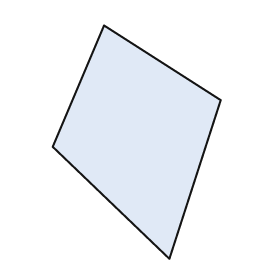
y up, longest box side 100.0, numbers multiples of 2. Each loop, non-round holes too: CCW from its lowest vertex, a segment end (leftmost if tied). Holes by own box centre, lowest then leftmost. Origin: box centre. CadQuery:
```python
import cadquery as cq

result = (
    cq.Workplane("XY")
    .moveTo(14.0, -50.0)
    .lineTo(36.0, 18.0)
    .lineTo(-14.0, 50.0)
    .lineTo(-36.0, -2.0)
    .close()
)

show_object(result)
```